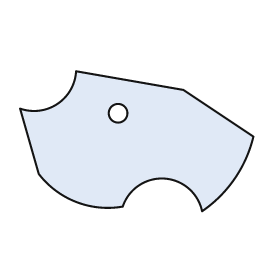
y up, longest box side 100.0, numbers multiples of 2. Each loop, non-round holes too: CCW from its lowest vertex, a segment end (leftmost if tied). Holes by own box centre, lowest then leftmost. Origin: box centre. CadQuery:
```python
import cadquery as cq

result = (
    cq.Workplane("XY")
    .moveTo(28.0, -30.0)
    .threePointArc((42.0, -16.0), (50.0, 2.0))
    .lineTo(20.0, 22.0)
    .lineTo(-26.0, 30.0)
    .threePointArc((-34.0, 16.0), (-50.0, 14.0))
    .lineTo(-42.0, -14.0)
    .threePointArc((-26.0, -26.0), (-6.0, -28.0))
    .threePointArc((12.0, -16.0), (28.0, -30.0))
    .close()
    .moveTo(-8.0, 12.0)
    .circle(4.0)
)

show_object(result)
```